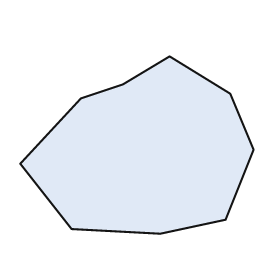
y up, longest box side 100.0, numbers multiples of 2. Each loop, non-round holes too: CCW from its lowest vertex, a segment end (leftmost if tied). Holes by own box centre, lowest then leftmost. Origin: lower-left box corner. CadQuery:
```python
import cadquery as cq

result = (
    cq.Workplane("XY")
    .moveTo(60.0, 0.0)
    .lineTo(88.0, 6.0)
    .lineTo(100.0, 36.0)
    .lineTo(90.0, 60.0)
    .lineTo(64.0, 76.0)
    .lineTo(44.0, 64.0)
    .lineTo(26.0, 58.0)
    .lineTo(0.0, 30.0)
    .lineTo(22.0, 2.0)
    .close()
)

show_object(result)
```